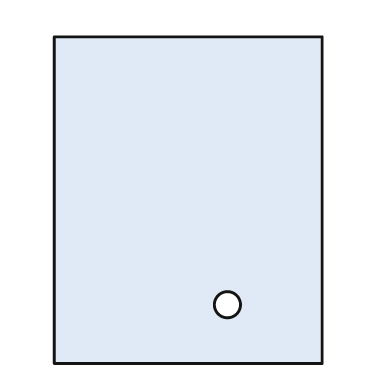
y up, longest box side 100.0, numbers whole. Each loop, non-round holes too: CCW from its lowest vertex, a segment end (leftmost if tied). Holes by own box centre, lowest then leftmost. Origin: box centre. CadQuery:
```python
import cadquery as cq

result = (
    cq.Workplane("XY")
    .moveTo(-41.0, -50.0)
    .lineTo(41.0, -50.0)
    .lineTo(41.0, 50.0)
    .lineTo(-41.0, 50.0)
    .close()
    .moveTo(12.0, -32.0)
    .circle(4.0)
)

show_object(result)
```